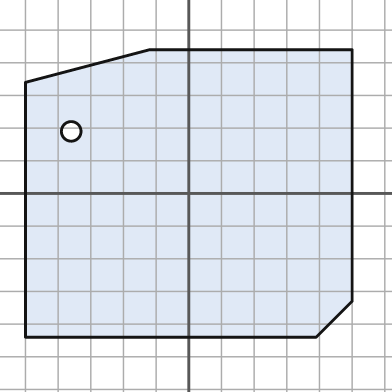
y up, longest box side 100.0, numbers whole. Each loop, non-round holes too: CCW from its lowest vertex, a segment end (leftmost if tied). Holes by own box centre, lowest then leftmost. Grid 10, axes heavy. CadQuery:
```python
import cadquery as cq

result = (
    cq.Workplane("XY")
    .moveTo(-50.0, -44.0)
    .lineTo(39.0, -44.0)
    .lineTo(50.0, -33.0)
    .lineTo(50.0, 44.0)
    .lineTo(-12.0, 44.0)
    .lineTo(-50.0, 34.0)
    .close()
    .moveTo(-36.0, 19.0)
    .circle(3.0)
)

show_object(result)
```